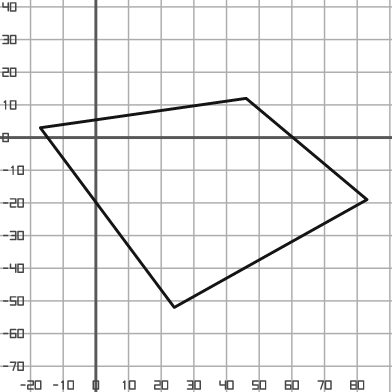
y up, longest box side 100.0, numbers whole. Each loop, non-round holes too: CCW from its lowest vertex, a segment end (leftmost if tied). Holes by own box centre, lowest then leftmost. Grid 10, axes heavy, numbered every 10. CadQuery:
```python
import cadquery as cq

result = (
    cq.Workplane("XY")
    .moveTo(24.0, -52.0)
    .lineTo(83.0, -19.0)
    .lineTo(46.0, 12.0)
    .lineTo(-17.0, 3.0)
    .close()
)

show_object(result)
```